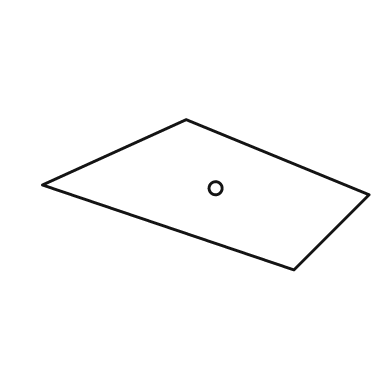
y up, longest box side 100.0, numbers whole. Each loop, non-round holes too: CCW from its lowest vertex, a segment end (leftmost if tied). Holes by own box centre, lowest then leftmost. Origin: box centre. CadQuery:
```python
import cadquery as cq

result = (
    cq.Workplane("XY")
    .moveTo(27.0, -23.0)
    .lineTo(50.0, 0.0)
    .lineTo(-6.0, 23.0)
    .lineTo(-50.0, 3.0)
    .close()
    .moveTo(3.0, 2.0)
    .circle(2.0)
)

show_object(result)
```